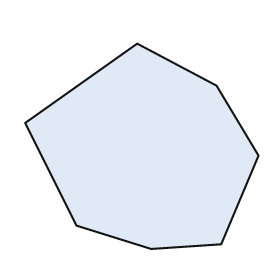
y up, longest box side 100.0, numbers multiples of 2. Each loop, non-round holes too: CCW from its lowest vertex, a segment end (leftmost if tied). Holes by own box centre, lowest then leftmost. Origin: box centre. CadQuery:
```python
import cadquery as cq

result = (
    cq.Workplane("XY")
    .moveTo(4.0, -44.0)
    .lineTo(34.0, -42.0)
    .lineTo(50.0, -4.0)
    .lineTo(32.0, 26.0)
    .lineTo(-2.0, 44.0)
    .lineTo(-50.0, 10.0)
    .lineTo(-28.0, -34.0)
    .close()
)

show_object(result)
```